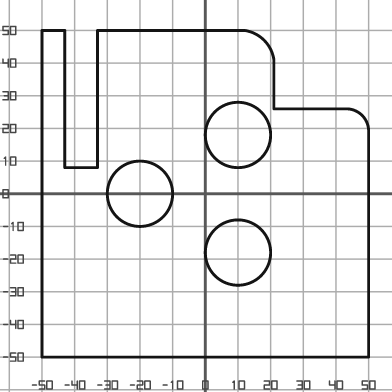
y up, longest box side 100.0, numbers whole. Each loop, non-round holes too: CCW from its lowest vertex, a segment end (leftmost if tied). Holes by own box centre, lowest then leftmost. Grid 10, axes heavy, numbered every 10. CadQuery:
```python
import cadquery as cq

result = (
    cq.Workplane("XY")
    .moveTo(-50.0, -50.0)
    .lineTo(50.0, -50.0)
    .lineTo(50.0, 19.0)
    .threePointArc((48.0, 24.0), (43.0, 26.0))
    .lineTo(21.0, 26.0)
    .lineTo(21.0, 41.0)
    .threePointArc((18.0, 47.0), (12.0, 50.0))
    .lineTo(-33.0, 50.0)
    .lineTo(-33.0, 8.0)
    .lineTo(-43.0, 8.0)
    .lineTo(-43.0, 50.0)
    .lineTo(-50.0, 50.0)
    .close()
    .moveTo(10.0, -18.0)
    .circle(10.0)
    .moveTo(-20.0, 0.0)
    .circle(10.0)
    .moveTo(10.0, 18.0)
    .circle(10.0)
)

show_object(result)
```